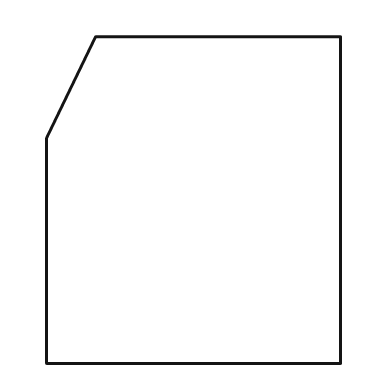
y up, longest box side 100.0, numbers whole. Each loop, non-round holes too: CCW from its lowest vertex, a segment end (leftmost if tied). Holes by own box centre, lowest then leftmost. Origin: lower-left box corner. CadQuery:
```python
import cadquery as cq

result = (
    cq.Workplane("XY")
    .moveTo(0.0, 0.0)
    .lineTo(90.0, 0.0)
    .lineTo(90.0, 100.0)
    .lineTo(15.0, 100.0)
    .lineTo(0.0, 69.0)
    .close()
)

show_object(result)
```